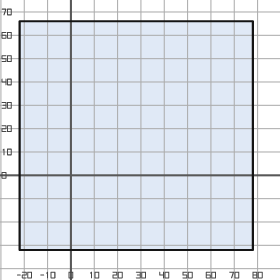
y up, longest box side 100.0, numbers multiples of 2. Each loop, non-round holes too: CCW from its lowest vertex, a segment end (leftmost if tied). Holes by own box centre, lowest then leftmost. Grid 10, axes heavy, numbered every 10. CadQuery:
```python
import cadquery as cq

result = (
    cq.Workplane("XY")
    .moveTo(-22.0, -32.0)
    .lineTo(78.0, -32.0)
    .lineTo(78.0, 66.0)
    .lineTo(-22.0, 66.0)
    .close()
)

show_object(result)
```